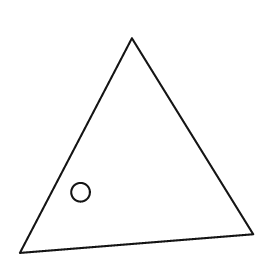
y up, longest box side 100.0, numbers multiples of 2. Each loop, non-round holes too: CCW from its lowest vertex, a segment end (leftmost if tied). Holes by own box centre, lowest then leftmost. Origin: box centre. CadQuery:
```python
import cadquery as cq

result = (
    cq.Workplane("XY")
    .moveTo(-50.0, -46.0)
    .lineTo(50.0, -38.0)
    .lineTo(-2.0, 46.0)
    .close()
    .moveTo(-24.0, -20.0)
    .circle(4.0)
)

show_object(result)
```